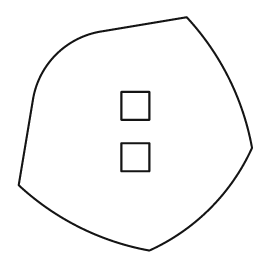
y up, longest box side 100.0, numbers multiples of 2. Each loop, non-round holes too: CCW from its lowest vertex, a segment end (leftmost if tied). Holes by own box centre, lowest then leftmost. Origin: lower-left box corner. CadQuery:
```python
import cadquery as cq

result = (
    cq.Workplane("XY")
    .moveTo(56.0, 0.0)
    .threePointArc((82.0, 18.0), (100.0, 44.0))
    .threePointArc((90.0, 74.0), (72.0, 100.0))
    .lineTo(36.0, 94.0)
    .threePointArc((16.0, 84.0), (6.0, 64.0))
    .lineTo(0.0, 28.0)
    .threePointArc((26.0, 10.0), (56.0, 0.0))
    .close()
    .moveTo(44.0, 34.0)
    .lineTo(56.0, 34.0)
    .lineTo(56.0, 46.0)
    .lineTo(44.0, 46.0)
    .close()
    .moveTo(44.0, 56.0)
    .lineTo(56.0, 56.0)
    .lineTo(56.0, 68.0)
    .lineTo(44.0, 68.0)
    .close()
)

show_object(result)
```